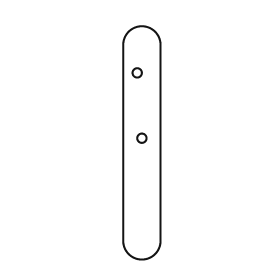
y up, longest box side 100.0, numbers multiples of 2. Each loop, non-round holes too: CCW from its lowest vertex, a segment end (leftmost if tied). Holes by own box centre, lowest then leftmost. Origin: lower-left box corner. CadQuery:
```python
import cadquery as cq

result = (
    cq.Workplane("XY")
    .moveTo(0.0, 8.0)
    .threePointArc((8.0, 0.0), (16.0, 8.0))
    .lineTo(16.0, 92.0)
    .threePointArc((8.0, 100.0), (0.0, 92.0))
    .close()
    .moveTo(8.0, 52.0)
    .circle(2.0)
    .moveTo(6.0, 80.0)
    .circle(2.0)
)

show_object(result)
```